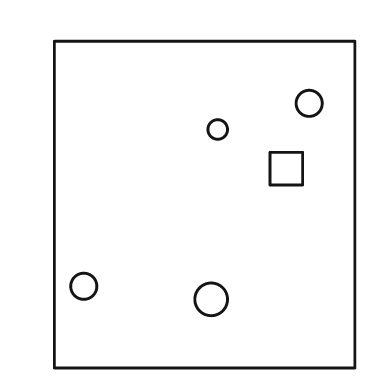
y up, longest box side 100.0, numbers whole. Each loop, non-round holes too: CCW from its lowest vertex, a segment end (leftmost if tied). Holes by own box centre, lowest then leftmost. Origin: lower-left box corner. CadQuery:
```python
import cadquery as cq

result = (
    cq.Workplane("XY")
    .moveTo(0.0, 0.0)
    .lineTo(92.0, 0.0)
    .lineTo(92.0, 100.0)
    .lineTo(0.0, 100.0)
    .close()
    .moveTo(48.0, 21.0)
    .circle(5.0)
    .moveTo(9.0, 25.0)
    .circle(4.0)
    .moveTo(66.0, 56.0)
    .lineTo(76.0, 56.0)
    .lineTo(76.0, 66.0)
    .lineTo(66.0, 66.0)
    .close()
    .moveTo(50.0, 73.0)
    .circle(3.0)
    .moveTo(78.0, 81.0)
    .circle(4.0)
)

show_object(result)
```